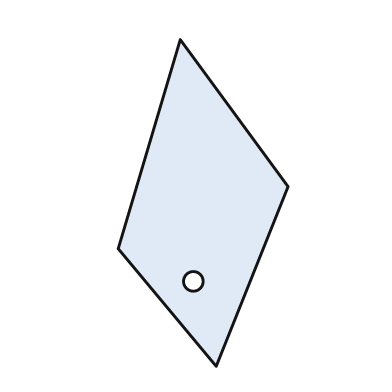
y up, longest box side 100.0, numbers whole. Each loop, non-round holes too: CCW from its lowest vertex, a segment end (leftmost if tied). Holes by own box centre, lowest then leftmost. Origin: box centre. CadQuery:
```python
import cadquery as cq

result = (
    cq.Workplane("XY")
    .moveTo(4.0, -50.0)
    .lineTo(26.0, 5.0)
    .lineTo(-7.0, 50.0)
    .lineTo(-26.0, -14.0)
    .close()
    .moveTo(-3.0, -24.0)
    .circle(3.0)
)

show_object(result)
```